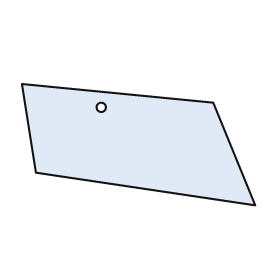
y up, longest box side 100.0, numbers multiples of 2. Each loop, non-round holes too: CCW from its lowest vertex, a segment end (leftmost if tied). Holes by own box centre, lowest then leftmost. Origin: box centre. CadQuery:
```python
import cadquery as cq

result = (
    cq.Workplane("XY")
    .moveTo(50.0, -26.0)
    .lineTo(32.0, 18.0)
    .lineTo(-50.0, 26.0)
    .lineTo(-44.0, -12.0)
    .close()
    .moveTo(-16.0, 16.0)
    .circle(2.0)
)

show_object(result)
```